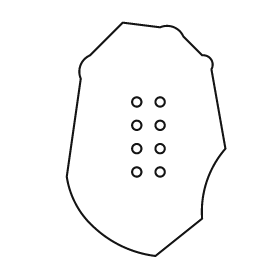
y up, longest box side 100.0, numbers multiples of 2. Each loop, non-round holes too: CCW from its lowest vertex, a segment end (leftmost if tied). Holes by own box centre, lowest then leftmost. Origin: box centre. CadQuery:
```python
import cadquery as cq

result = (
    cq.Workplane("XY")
    .moveTo(4.0, -50.0)
    .lineTo(24.0, -34.0)
    .threePointArc((26.0, -18.0), (34.0, -4.0))
    .lineTo(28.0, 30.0)
    .threePointArc((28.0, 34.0), (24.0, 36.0))
    .lineTo(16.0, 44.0)
    .threePointArc((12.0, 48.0), (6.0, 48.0))
    .lineTo(-10.0, 50.0)
    .lineTo(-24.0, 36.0)
    .threePointArc((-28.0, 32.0), (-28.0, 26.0))
    .lineTo(-34.0, -16.0)
    .threePointArc((-30.0, -28.0), (-22.0, -38.0))
    .threePointArc((-10.0, -46.0), (4.0, -50.0))
    .close()
    .moveTo(-4.0, -14.0)
    .circle(2.0)
    .moveTo(6.0, -14.0)
    .circle(2.0)
    .moveTo(-4.0, -4.0)
    .circle(2.0)
    .moveTo(6.0, -4.0)
    .circle(2.0)
    .moveTo(-4.0, 6.0)
    .circle(2.0)
    .moveTo(6.0, 6.0)
    .circle(2.0)
    .moveTo(-4.0, 16.0)
    .circle(2.0)
    .moveTo(6.0, 16.0)
    .circle(2.0)
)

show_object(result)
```